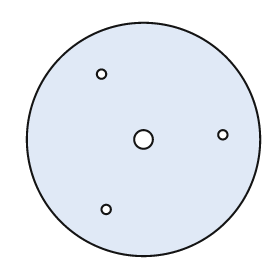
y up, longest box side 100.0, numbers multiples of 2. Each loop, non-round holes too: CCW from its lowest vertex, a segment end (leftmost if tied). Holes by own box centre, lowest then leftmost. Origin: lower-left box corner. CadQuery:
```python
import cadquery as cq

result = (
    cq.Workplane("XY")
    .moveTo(50.0, 50.0)
    .circle(50.0)
    .moveTo(34.0, 20.0)
    .circle(2.0)
    .moveTo(50.0, 50.0)
    .circle(4.0)
    .moveTo(84.0, 52.0)
    .circle(2.0)
    .moveTo(32.0, 78.0)
    .circle(2.0)
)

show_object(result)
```